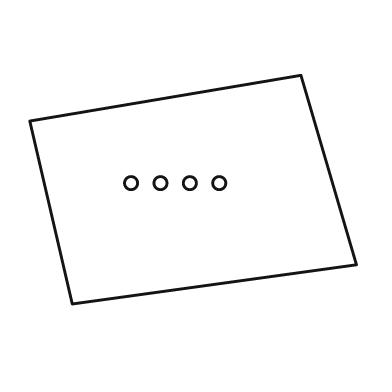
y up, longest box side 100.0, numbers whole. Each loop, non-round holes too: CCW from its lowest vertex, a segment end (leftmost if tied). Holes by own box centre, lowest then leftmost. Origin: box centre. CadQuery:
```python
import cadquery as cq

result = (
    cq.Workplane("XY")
    .moveTo(-37.0, -35.0)
    .lineTo(50.0, -23.0)
    .lineTo(33.0, 35.0)
    .lineTo(-50.0, 21.0)
    .close()
    .moveTo(-19.0, 2.0)
    .circle(2.0)
    .moveTo(-10.0, 2.0)
    .circle(2.0)
    .moveTo(-1.0, 2.0)
    .circle(2.0)
    .moveTo(8.0, 2.0)
    .circle(2.0)
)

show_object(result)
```